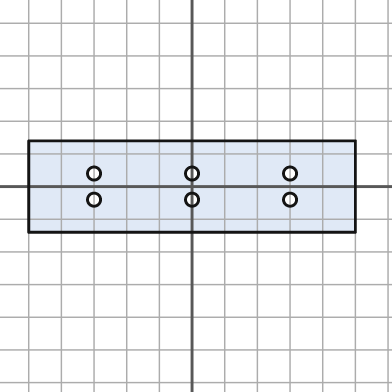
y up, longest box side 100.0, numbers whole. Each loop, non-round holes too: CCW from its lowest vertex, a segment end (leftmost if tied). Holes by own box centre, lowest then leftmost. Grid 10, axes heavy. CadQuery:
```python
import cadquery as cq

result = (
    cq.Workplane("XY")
    .moveTo(-50.0, -14.0)
    .lineTo(50.0, -14.0)
    .lineTo(50.0, 14.0)
    .lineTo(-50.0, 14.0)
    .close()
    .moveTo(-30.0, -4.0)
    .circle(2.0)
    .moveTo(0.0, -4.0)
    .circle(2.0)
    .moveTo(30.0, -4.0)
    .circle(2.0)
    .moveTo(-30.0, 4.0)
    .circle(2.0)
    .moveTo(0.0, 4.0)
    .circle(2.0)
    .moveTo(30.0, 4.0)
    .circle(2.0)
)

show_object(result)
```